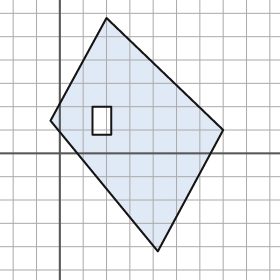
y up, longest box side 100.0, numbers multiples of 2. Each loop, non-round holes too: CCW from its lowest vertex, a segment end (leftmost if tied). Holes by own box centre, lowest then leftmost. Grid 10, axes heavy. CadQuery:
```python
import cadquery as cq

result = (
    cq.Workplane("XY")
    .moveTo(42.0, -42.0)
    .lineTo(70.0, 10.0)
    .lineTo(20.0, 58.0)
    .lineTo(-4.0, 14.0)
    .close()
    .moveTo(14.0, 8.0)
    .lineTo(22.0, 8.0)
    .lineTo(22.0, 20.0)
    .lineTo(14.0, 20.0)
    .close()
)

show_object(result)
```